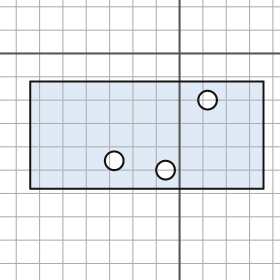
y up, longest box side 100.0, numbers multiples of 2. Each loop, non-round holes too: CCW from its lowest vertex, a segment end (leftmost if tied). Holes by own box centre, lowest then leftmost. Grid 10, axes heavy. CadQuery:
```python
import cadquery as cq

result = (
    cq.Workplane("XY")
    .moveTo(-64.0, -58.0)
    .lineTo(36.0, -58.0)
    .lineTo(36.0, -12.0)
    .lineTo(-64.0, -12.0)
    .close()
    .moveTo(-6.0, -50.0)
    .circle(4.0)
    .moveTo(-28.0, -46.0)
    .circle(4.0)
    .moveTo(12.0, -20.0)
    .circle(4.0)
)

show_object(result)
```